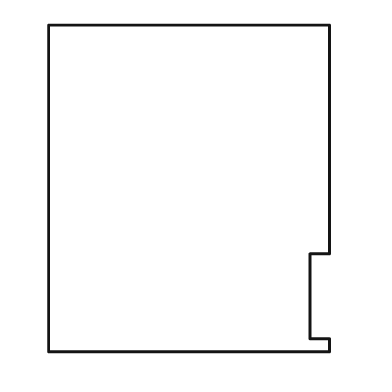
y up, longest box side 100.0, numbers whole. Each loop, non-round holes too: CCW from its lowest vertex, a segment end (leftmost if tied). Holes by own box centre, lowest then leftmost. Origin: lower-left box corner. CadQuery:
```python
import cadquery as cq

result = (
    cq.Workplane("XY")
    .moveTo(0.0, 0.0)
    .lineTo(86.0, 0.0)
    .lineTo(86.0, 4.0)
    .lineTo(80.0, 4.0)
    .lineTo(80.0, 30.0)
    .lineTo(86.0, 30.0)
    .lineTo(86.0, 100.0)
    .lineTo(0.0, 100.0)
    .close()
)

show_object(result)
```